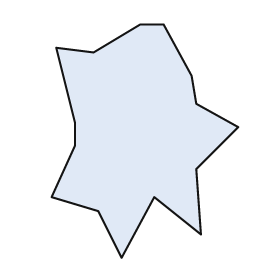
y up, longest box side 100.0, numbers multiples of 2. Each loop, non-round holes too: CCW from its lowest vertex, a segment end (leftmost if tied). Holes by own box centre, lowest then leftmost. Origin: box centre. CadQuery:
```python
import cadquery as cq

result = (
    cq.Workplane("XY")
    .moveTo(-10.0, -50.0)
    .lineTo(4.0, -24.0)
    .lineTo(24.0, -40.0)
    .lineTo(22.0, -12.0)
    .lineTo(40.0, 6.0)
    .lineTo(22.0, 16.0)
    .lineTo(20.0, 28.0)
    .lineTo(8.0, 50.0)
    .lineTo(-2.0, 50.0)
    .lineTo(-22.0, 38.0)
    .lineTo(-38.0, 40.0)
    .lineTo(-30.0, 8.0)
    .lineTo(-30.0, -2.0)
    .lineTo(-40.0, -24.0)
    .lineTo(-20.0, -30.0)
    .close()
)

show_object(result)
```